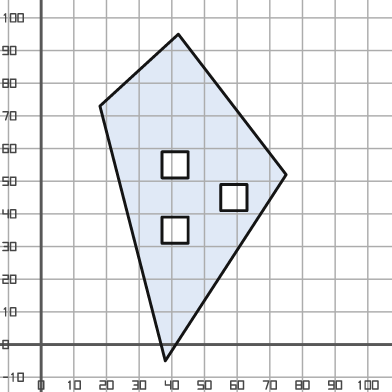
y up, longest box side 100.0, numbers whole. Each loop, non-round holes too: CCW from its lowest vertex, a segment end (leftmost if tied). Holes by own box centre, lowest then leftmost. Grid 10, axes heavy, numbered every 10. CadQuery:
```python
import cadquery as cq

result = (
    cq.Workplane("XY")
    .moveTo(38.0, -5.0)
    .lineTo(75.0, 52.0)
    .lineTo(42.0, 95.0)
    .lineTo(18.0, 73.0)
    .close()
    .moveTo(37.0, 31.0)
    .lineTo(45.0, 31.0)
    .lineTo(45.0, 39.0)
    .lineTo(37.0, 39.0)
    .close()
    .moveTo(55.0, 41.0)
    .lineTo(63.0, 41.0)
    .lineTo(63.0, 49.0)
    .lineTo(55.0, 49.0)
    .close()
    .moveTo(37.0, 51.0)
    .lineTo(45.0, 51.0)
    .lineTo(45.0, 59.0)
    .lineTo(37.0, 59.0)
    .close()
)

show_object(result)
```